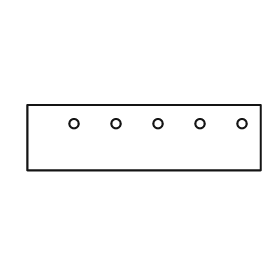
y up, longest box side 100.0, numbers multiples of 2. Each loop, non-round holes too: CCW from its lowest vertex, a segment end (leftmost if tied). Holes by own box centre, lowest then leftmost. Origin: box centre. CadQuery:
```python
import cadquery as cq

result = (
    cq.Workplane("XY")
    .moveTo(-50.0, -14.0)
    .lineTo(50.0, -14.0)
    .lineTo(50.0, 14.0)
    .lineTo(-50.0, 14.0)
    .close()
    .moveTo(-30.0, 6.0)
    .circle(2.0)
    .moveTo(-12.0, 6.0)
    .circle(2.0)
    .moveTo(6.0, 6.0)
    .circle(2.0)
    .moveTo(24.0, 6.0)
    .circle(2.0)
    .moveTo(42.0, 6.0)
    .circle(2.0)
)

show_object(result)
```